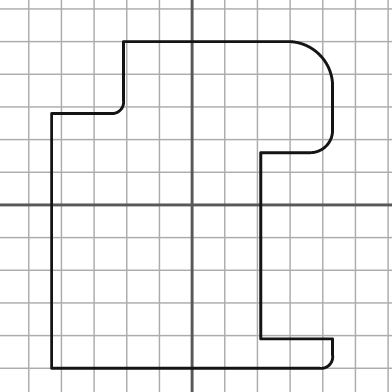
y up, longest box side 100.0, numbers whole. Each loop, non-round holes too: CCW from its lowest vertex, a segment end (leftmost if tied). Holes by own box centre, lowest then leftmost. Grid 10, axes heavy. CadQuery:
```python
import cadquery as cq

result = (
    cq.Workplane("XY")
    .moveTo(-43.0, -50.0)
    .lineTo(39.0, -50.0)
    .threePointArc((42.0, -49.0), (43.0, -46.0))
    .lineTo(43.0, -41.0)
    .lineTo(21.0, -41.0)
    .lineTo(21.0, 16.0)
    .lineTo(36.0, 16.0)
    .threePointArc((41.0, 18.0), (43.0, 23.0))
    .lineTo(43.0, 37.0)
    .threePointArc((39.0, 46.0), (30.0, 50.0))
    .lineTo(-21.0, 50.0)
    .lineTo(-21.0, 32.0)
    .threePointArc((-22.0, 29.0), (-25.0, 28.0))
    .lineTo(-43.0, 28.0)
    .close()
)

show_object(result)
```